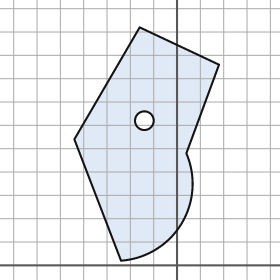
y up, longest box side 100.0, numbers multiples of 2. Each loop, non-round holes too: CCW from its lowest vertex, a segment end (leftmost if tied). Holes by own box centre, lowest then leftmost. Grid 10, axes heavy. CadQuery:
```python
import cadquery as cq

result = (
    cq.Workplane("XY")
    .moveTo(-24.0, 2.0)
    .threePointArc((2.0, 18.0), (4.0, 48.0))
    .lineTo(18.0, 86.0)
    .lineTo(-16.0, 102.0)
    .lineTo(-44.0, 54.0)
    .close()
    .moveTo(-14.0, 62.0)
    .circle(4.0)
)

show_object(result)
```